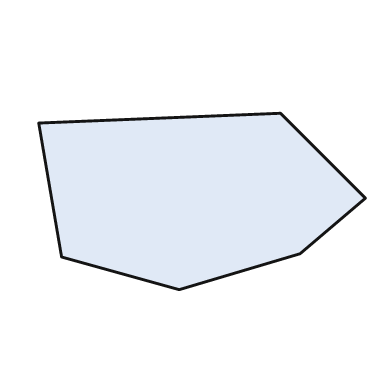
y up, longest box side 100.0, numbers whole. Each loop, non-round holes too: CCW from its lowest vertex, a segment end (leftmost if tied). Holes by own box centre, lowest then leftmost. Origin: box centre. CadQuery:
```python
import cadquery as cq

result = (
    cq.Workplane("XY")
    .moveTo(-7.0, -27.0)
    .lineTo(30.0, -16.0)
    .lineTo(50.0, 1.0)
    .lineTo(24.0, 27.0)
    .lineTo(-50.0, 24.0)
    .lineTo(-43.0, -17.0)
    .close()
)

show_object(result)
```